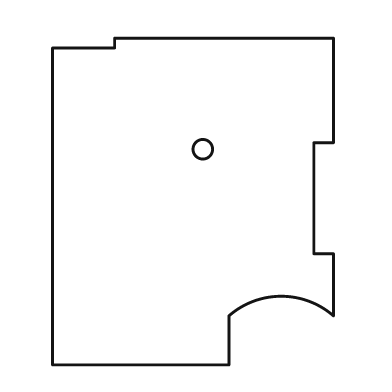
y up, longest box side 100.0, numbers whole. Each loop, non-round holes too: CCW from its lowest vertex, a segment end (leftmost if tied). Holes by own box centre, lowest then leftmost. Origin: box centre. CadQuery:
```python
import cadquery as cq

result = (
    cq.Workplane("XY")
    .moveTo(-43.0, -50.0)
    .lineTo(11.0, -50.0)
    .lineTo(11.0, -35.0)
    .threePointArc((27.0, -29.0), (43.0, -35.0))
    .lineTo(43.0, -16.0)
    .lineTo(37.0, -16.0)
    .lineTo(37.0, 18.0)
    .lineTo(43.0, 18.0)
    .lineTo(43.0, 50.0)
    .lineTo(-24.0, 50.0)
    .lineTo(-24.0, 47.0)
    .lineTo(-43.0, 47.0)
    .close()
    .moveTo(3.0, 16.0)
    .circle(3.0)
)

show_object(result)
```